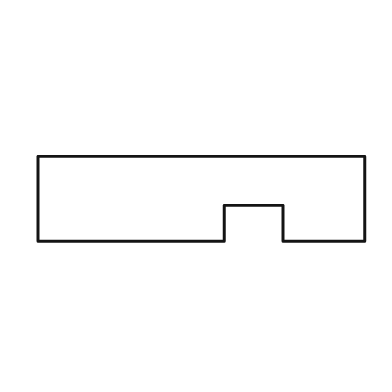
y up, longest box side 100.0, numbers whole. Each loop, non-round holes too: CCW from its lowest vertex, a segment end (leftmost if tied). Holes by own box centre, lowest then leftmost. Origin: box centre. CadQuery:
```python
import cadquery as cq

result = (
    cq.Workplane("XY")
    .moveTo(-50.0, -13.0)
    .lineTo(7.0, -13.0)
    .lineTo(7.0, -2.0)
    .lineTo(25.0, -2.0)
    .lineTo(25.0, -13.0)
    .lineTo(50.0, -13.0)
    .lineTo(50.0, 13.0)
    .lineTo(-50.0, 13.0)
    .close()
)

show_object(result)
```